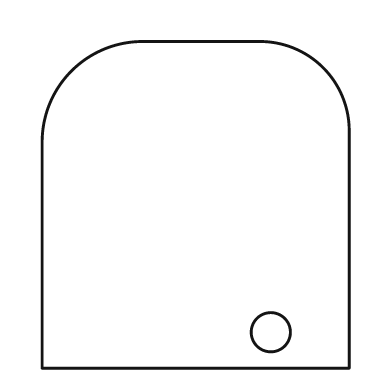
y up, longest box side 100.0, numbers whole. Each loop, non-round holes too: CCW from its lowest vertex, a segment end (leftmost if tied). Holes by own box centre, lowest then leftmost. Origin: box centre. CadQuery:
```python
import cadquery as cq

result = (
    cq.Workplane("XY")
    .moveTo(-47.0, -50.0)
    .lineTo(47.0, -50.0)
    .lineTo(47.0, 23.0)
    .threePointArc((39.0, 42.0), (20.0, 50.0))
    .lineTo(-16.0, 50.0)
    .threePointArc((-38.0, 41.0), (-47.0, 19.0))
    .close()
    .moveTo(23.0, -39.0)
    .circle(6.0)
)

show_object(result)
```